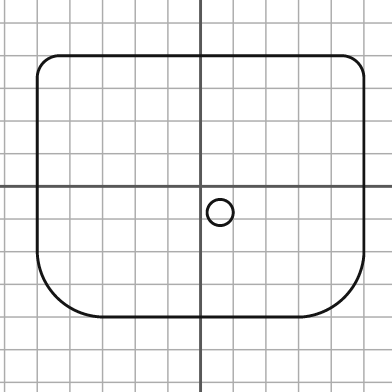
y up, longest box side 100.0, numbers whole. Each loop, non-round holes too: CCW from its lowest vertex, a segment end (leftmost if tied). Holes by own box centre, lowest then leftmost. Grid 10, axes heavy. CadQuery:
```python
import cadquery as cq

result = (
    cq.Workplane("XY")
    .moveTo(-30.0, -40.0)
    .lineTo(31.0, -40.0)
    .threePointArc((44.0, -34.0), (50.0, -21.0))
    .lineTo(50.0, 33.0)
    .threePointArc((48.0, 38.0), (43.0, 40.0))
    .lineTo(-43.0, 40.0)
    .threePointArc((-48.0, 38.0), (-50.0, 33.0))
    .lineTo(-50.0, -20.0)
    .threePointArc((-44.0, -34.0), (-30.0, -40.0))
    .close()
    .moveTo(6.0, -8.0)
    .circle(4.0)
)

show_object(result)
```